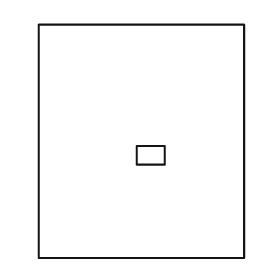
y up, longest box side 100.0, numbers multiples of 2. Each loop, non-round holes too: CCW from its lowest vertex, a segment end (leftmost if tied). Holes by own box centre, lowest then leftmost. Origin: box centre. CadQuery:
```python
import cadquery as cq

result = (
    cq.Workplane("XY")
    .moveTo(-44.0, -50.0)
    .lineTo(44.0, -50.0)
    .lineTo(44.0, 50.0)
    .lineTo(-44.0, 50.0)
    .close()
    .moveTo(-2.0, -10.0)
    .lineTo(10.0, -10.0)
    .lineTo(10.0, -2.0)
    .lineTo(-2.0, -2.0)
    .close()
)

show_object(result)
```